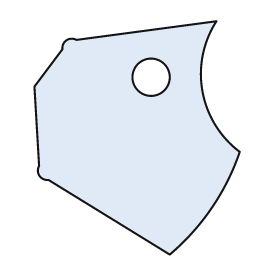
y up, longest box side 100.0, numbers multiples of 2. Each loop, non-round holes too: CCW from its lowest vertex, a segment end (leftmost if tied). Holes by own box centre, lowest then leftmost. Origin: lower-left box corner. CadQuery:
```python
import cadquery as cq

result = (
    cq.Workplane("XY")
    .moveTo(58.0, 0.0)
    .threePointArc((76.0, 20.0), (88.0, 44.0))
    .threePointArc((72.0, 70.0), (78.0, 100.0))
    .lineTo(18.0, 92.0)
    .threePointArc((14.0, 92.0), (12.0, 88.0))
    .lineTo(0.0, 72.0)
    .lineTo(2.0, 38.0)
    .threePointArc((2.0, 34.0), (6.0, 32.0))
    .close()
    .moveTo(50.0, 76.0)
    .circle(8.0)
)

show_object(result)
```